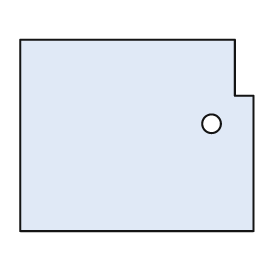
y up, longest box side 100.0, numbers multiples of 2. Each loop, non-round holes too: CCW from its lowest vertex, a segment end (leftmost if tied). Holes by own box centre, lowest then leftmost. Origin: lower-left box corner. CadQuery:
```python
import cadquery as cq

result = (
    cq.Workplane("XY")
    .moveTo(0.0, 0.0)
    .lineTo(100.0, 0.0)
    .lineTo(100.0, 58.0)
    .lineTo(92.0, 58.0)
    .lineTo(92.0, 82.0)
    .lineTo(0.0, 82.0)
    .close()
    .moveTo(82.0, 46.0)
    .circle(4.0)
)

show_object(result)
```